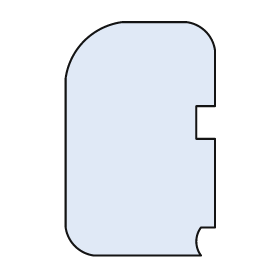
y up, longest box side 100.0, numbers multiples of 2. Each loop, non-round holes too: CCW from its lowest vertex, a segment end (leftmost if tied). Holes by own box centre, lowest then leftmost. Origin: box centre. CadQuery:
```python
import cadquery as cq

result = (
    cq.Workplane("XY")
    .moveTo(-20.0, -50.0)
    .lineTo(26.0, -50.0)
    .threePointArc((24.0, -44.0), (26.0, -38.0))
    .lineTo(32.0, -38.0)
    .lineTo(32.0, 0.0)
    .lineTo(24.0, 0.0)
    .lineTo(24.0, 14.0)
    .lineTo(32.0, 14.0)
    .lineTo(32.0, 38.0)
    .threePointArc((28.0, 46.0), (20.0, 50.0))
    .lineTo(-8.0, 50.0)
    .threePointArc((-24.0, 42.0), (-32.0, 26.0))
    .lineTo(-32.0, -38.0)
    .threePointArc((-28.0, -46.0), (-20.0, -50.0))
    .close()
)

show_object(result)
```